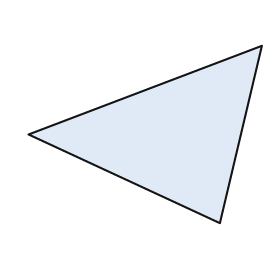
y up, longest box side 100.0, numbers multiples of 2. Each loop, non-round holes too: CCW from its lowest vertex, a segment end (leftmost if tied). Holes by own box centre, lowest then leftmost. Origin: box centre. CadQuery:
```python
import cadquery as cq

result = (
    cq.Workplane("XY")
    .moveTo(32.0, -38.0)
    .lineTo(50.0, 38.0)
    .lineTo(-50.0, 0.0)
    .close()
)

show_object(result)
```